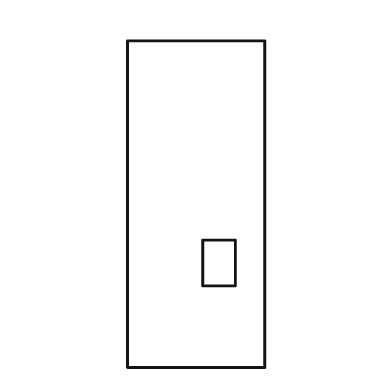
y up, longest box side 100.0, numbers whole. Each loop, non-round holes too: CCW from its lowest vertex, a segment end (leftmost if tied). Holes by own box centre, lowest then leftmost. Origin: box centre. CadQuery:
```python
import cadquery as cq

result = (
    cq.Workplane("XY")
    .moveTo(-21.0, -50.0)
    .lineTo(21.0, -50.0)
    .lineTo(21.0, 50.0)
    .lineTo(-21.0, 50.0)
    .close()
    .moveTo(2.0, -25.0)
    .lineTo(12.0, -25.0)
    .lineTo(12.0, -11.0)
    .lineTo(2.0, -11.0)
    .close()
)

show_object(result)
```